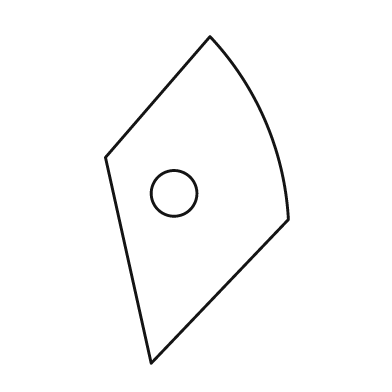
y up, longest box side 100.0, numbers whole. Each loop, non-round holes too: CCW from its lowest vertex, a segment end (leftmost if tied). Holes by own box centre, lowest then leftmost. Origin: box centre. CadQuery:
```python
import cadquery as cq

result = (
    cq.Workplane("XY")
    .moveTo(-14.0, -50.0)
    .lineTo(28.0, -6.0)
    .threePointArc((21.0, 24.0), (4.0, 50.0))
    .lineTo(-28.0, 13.0)
    .close()
    .moveTo(-7.0, 2.0)
    .circle(7.0)
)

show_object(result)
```